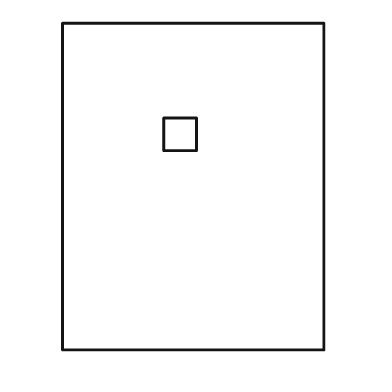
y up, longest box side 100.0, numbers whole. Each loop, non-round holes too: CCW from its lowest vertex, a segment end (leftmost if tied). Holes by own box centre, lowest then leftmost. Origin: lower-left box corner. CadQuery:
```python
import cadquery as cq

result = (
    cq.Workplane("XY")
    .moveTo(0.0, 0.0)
    .lineTo(80.0, 0.0)
    .lineTo(80.0, 100.0)
    .lineTo(0.0, 100.0)
    .close()
    .moveTo(31.0, 61.0)
    .lineTo(41.0, 61.0)
    .lineTo(41.0, 71.0)
    .lineTo(31.0, 71.0)
    .close()
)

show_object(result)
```